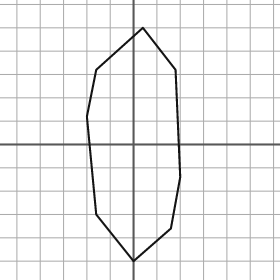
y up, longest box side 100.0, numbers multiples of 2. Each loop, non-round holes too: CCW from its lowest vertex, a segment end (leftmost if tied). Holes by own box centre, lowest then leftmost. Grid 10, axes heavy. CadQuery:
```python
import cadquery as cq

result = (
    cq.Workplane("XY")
    .moveTo(0.0, -50.0)
    .lineTo(16.0, -36.0)
    .lineTo(20.0, -14.0)
    .lineTo(18.0, 32.0)
    .lineTo(4.0, 50.0)
    .lineTo(-16.0, 32.0)
    .lineTo(-20.0, 12.0)
    .lineTo(-16.0, -30.0)
    .close()
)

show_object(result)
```